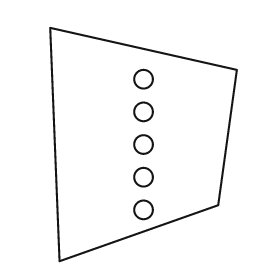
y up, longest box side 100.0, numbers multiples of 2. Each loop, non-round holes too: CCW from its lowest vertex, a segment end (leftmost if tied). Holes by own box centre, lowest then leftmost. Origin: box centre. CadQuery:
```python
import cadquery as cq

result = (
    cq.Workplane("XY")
    .moveTo(-36.0, -50.0)
    .lineTo(32.0, -26.0)
    .lineTo(40.0, 32.0)
    .lineTo(-40.0, 50.0)
    .close()
    .moveTo(0.0, -28.0)
    .circle(4.0)
    .moveTo(0.0, -14.0)
    .circle(4.0)
    .moveTo(0.0, 0.0)
    .circle(4.0)
    .moveTo(0.0, 14.0)
    .circle(4.0)
    .moveTo(0.0, 28.0)
    .circle(4.0)
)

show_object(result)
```